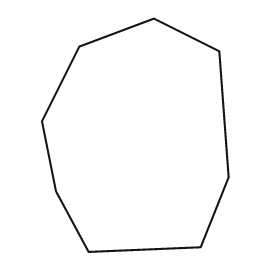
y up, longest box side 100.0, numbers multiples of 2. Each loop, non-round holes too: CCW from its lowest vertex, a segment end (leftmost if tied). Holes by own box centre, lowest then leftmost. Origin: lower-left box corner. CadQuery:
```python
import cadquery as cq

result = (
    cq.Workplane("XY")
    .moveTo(20.0, 0.0)
    .lineTo(68.0, 2.0)
    .lineTo(80.0, 32.0)
    .lineTo(76.0, 86.0)
    .lineTo(48.0, 100.0)
    .lineTo(16.0, 88.0)
    .lineTo(0.0, 56.0)
    .lineTo(6.0, 26.0)
    .close()
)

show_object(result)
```